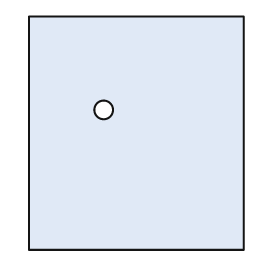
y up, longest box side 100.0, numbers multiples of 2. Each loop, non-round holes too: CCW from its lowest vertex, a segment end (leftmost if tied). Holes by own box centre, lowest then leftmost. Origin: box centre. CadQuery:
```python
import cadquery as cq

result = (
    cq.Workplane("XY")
    .moveTo(-46.0, -50.0)
    .lineTo(46.0, -50.0)
    .lineTo(46.0, 50.0)
    .lineTo(-46.0, 50.0)
    .close()
    .moveTo(-14.0, 10.0)
    .circle(4.0)
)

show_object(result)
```